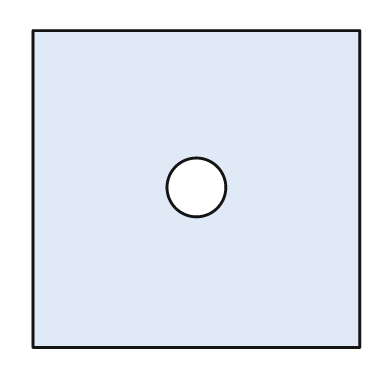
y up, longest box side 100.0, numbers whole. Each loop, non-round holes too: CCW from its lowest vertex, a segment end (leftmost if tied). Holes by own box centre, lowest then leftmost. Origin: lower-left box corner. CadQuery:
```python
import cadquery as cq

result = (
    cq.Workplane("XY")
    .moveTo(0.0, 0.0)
    .lineTo(100.0, 0.0)
    .lineTo(100.0, 97.0)
    .lineTo(0.0, 97.0)
    .close()
    .moveTo(50.0, 49.0)
    .circle(9.0)
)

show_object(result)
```